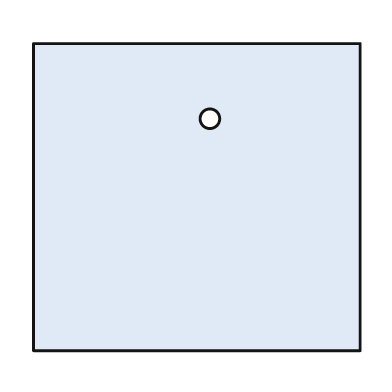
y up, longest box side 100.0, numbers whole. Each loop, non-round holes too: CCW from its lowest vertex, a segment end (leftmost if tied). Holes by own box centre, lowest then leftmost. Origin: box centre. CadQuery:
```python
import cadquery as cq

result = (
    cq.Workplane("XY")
    .moveTo(-50.0, -47.0)
    .lineTo(50.0, -47.0)
    .lineTo(50.0, 47.0)
    .lineTo(-50.0, 47.0)
    .close()
    .moveTo(4.0, 24.0)
    .circle(3.0)
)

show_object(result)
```